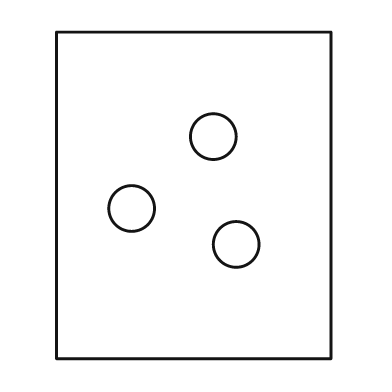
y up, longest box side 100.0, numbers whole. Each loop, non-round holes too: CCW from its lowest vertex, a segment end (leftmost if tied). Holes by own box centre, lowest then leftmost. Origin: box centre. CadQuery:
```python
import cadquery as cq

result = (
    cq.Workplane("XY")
    .moveTo(-42.0, -50.0)
    .lineTo(42.0, -50.0)
    .lineTo(42.0, 50.0)
    .lineTo(-42.0, 50.0)
    .close()
    .moveTo(13.0, -15.0)
    .circle(7.0)
    .moveTo(-19.0, -4.0)
    .circle(7.0)
    .moveTo(6.0, 18.0)
    .circle(7.0)
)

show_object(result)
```